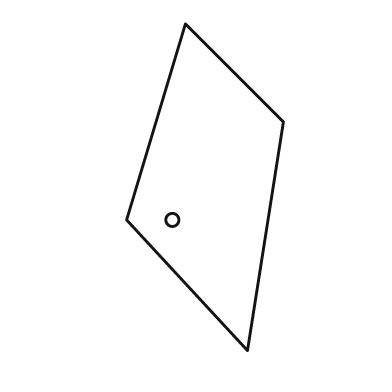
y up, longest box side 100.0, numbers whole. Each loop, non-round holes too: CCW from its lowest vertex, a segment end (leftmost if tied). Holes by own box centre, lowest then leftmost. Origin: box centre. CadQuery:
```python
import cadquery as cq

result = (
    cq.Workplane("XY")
    .moveTo(13.0, -50.0)
    .lineTo(24.0, 20.0)
    .lineTo(-6.0, 50.0)
    .lineTo(-24.0, -10.0)
    .close()
    .moveTo(-10.0, -10.0)
    .circle(2.0)
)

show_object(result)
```